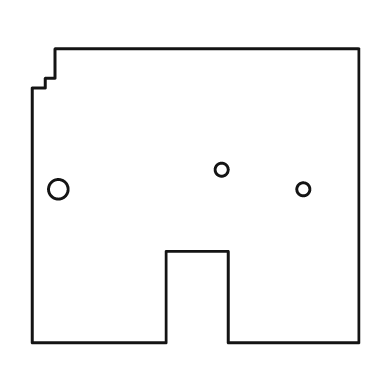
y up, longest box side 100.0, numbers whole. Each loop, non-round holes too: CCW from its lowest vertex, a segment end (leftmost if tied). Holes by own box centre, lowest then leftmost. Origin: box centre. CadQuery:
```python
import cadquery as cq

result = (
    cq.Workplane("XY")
    .moveTo(-50.0, -45.0)
    .lineTo(-9.0, -45.0)
    .lineTo(-9.0, -17.0)
    .lineTo(10.0, -17.0)
    .lineTo(10.0, -45.0)
    .lineTo(50.0, -45.0)
    .lineTo(50.0, 45.0)
    .lineTo(-43.0, 45.0)
    .lineTo(-43.0, 36.0)
    .lineTo(-46.0, 36.0)
    .lineTo(-46.0, 33.0)
    .lineTo(-50.0, 33.0)
    .close()
    .moveTo(-42.0, 2.0)
    .circle(3.0)
    .moveTo(33.0, 2.0)
    .circle(2.0)
    .moveTo(8.0, 8.0)
    .circle(2.0)
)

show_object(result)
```